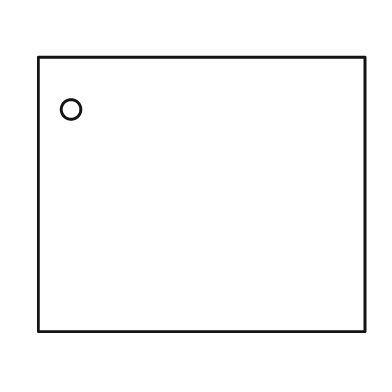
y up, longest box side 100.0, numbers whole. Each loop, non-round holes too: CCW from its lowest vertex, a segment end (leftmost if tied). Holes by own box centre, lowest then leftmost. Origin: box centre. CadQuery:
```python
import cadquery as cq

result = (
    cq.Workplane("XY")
    .moveTo(-50.0, -42.0)
    .lineTo(50.0, -42.0)
    .lineTo(50.0, 42.0)
    .lineTo(-50.0, 42.0)
    .close()
    .moveTo(-40.0, 26.0)
    .circle(3.0)
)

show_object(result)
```